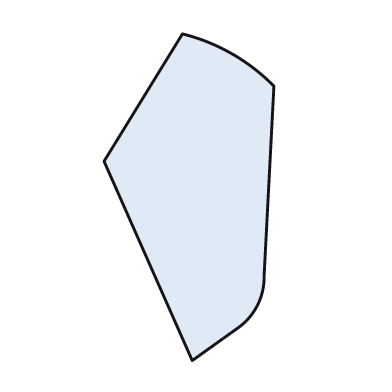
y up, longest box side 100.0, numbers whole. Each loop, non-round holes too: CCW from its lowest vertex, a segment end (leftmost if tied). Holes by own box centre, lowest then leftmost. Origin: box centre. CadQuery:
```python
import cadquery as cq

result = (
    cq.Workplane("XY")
    .moveTo(1.0, -50.0)
    .lineTo(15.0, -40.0)
    .threePointArc((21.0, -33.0), (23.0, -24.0))
    .lineTo(26.0, 34.0)
    .threePointArc((13.0, 44.0), (-2.0, 50.0))
    .lineTo(-26.0, 11.0)
    .close()
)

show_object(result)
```